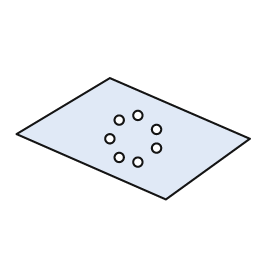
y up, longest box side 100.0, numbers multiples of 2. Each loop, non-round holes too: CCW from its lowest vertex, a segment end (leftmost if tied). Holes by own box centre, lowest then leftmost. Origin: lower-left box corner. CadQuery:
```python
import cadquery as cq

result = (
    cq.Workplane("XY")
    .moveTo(64.0, 0.0)
    .lineTo(100.0, 26.0)
    .lineTo(40.0, 52.0)
    .lineTo(0.0, 28.0)
    .close()
    .moveTo(52.0, 16.0)
    .circle(2.0)
    .moveTo(44.0, 18.0)
    .circle(2.0)
    .moveTo(60.0, 22.0)
    .circle(2.0)
    .moveTo(40.0, 26.0)
    .circle(2.0)
    .moveTo(60.0, 30.0)
    .circle(2.0)
    .moveTo(44.0, 34.0)
    .circle(2.0)
    .moveTo(52.0, 36.0)
    .circle(2.0)
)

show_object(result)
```